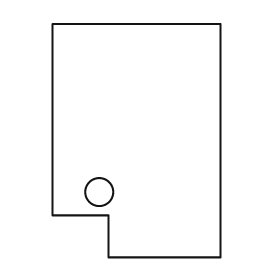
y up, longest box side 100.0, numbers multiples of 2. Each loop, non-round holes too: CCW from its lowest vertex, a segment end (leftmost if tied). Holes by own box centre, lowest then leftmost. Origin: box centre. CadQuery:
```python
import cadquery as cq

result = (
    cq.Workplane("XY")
    .moveTo(-12.0, -50.0)
    .lineTo(36.0, -50.0)
    .lineTo(36.0, 50.0)
    .lineTo(-36.0, 50.0)
    .lineTo(-36.0, -32.0)
    .lineTo(-12.0, -32.0)
    .close()
    .moveTo(-16.0, -22.0)
    .circle(6.0)
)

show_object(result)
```